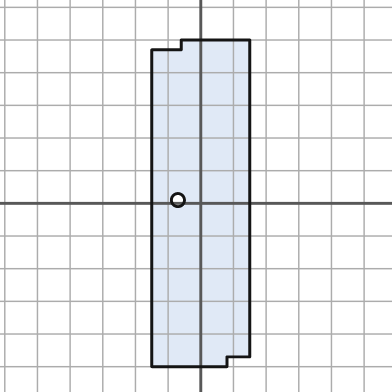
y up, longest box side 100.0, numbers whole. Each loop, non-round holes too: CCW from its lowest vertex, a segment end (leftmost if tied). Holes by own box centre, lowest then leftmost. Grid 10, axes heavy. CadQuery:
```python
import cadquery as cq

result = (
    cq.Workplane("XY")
    .moveTo(-15.0, -50.0)
    .lineTo(8.0, -50.0)
    .lineTo(8.0, -47.0)
    .lineTo(15.0, -47.0)
    .lineTo(15.0, 50.0)
    .lineTo(-6.0, 50.0)
    .lineTo(-6.0, 47.0)
    .lineTo(-15.0, 47.0)
    .close()
    .moveTo(-7.0, 1.0)
    .circle(2.0)
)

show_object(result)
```